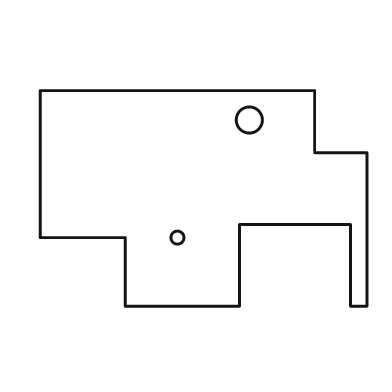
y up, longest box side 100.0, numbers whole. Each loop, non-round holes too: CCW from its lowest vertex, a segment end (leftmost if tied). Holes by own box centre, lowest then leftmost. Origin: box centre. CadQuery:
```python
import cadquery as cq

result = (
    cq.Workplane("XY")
    .moveTo(-24.0, -33.0)
    .lineTo(11.0, -33.0)
    .lineTo(11.0, -8.0)
    .lineTo(45.0, -8.0)
    .lineTo(45.0, -33.0)
    .lineTo(50.0, -33.0)
    .lineTo(50.0, 14.0)
    .lineTo(34.0, 14.0)
    .lineTo(34.0, 33.0)
    .lineTo(-50.0, 33.0)
    .lineTo(-50.0, -12.0)
    .lineTo(-24.0, -12.0)
    .close()
    .moveTo(-8.0, -12.0)
    .circle(2.0)
    .moveTo(14.0, 24.0)
    .circle(4.0)
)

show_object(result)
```